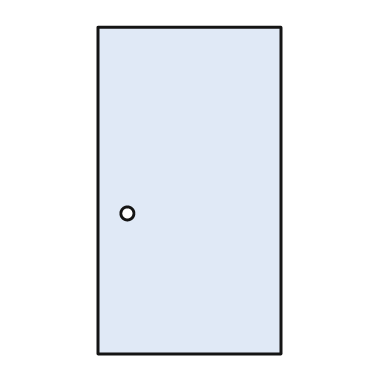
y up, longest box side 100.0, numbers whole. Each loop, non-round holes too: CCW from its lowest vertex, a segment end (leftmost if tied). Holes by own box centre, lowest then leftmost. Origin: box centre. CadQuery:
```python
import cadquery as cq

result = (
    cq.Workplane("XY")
    .moveTo(-28.0, -50.0)
    .lineTo(28.0, -50.0)
    .lineTo(28.0, 50.0)
    .lineTo(-28.0, 50.0)
    .close()
    .moveTo(-19.0, -7.0)
    .circle(2.0)
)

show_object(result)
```